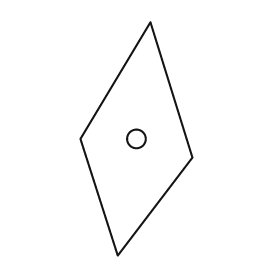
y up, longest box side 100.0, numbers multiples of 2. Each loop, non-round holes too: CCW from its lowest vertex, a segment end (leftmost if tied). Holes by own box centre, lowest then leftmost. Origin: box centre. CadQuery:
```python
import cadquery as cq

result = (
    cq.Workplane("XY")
    .moveTo(-8.0, -50.0)
    .lineTo(24.0, -8.0)
    .lineTo(6.0, 50.0)
    .lineTo(-24.0, 0.0)
    .close()
    .moveTo(0.0, 0.0)
    .circle(4.0)
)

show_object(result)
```